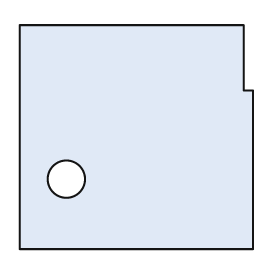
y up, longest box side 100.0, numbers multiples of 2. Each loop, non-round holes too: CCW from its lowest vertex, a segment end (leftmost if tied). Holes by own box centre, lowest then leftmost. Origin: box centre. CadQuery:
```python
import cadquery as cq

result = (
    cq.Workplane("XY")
    .moveTo(-50.0, -48.0)
    .lineTo(50.0, -48.0)
    .lineTo(50.0, 20.0)
    .lineTo(46.0, 20.0)
    .lineTo(46.0, 48.0)
    .lineTo(-50.0, 48.0)
    .close()
    .moveTo(-30.0, -18.0)
    .circle(8.0)
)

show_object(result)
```